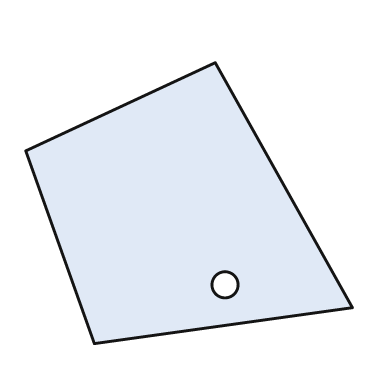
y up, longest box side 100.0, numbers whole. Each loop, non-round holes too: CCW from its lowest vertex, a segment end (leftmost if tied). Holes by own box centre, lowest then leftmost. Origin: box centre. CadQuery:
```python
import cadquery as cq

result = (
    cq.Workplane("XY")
    .moveTo(-29.0, -43.0)
    .lineTo(50.0, -32.0)
    .lineTo(8.0, 43.0)
    .lineTo(-50.0, 16.0)
    .close()
    .moveTo(11.0, -25.0)
    .circle(4.0)
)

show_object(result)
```